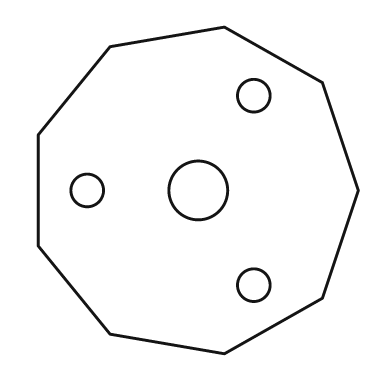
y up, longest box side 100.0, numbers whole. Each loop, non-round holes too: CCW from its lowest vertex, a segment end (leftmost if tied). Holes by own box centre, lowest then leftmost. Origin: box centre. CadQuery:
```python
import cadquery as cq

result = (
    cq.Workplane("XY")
    .moveTo(8.0, -50.0)
    .lineTo(38.0, -33.0)
    .lineTo(49.0, 0.0)
    .lineTo(38.0, 33.0)
    .lineTo(8.0, 50.0)
    .lineTo(-27.0, 44.0)
    .lineTo(-49.0, 17.0)
    .lineTo(-49.0, -17.0)
    .lineTo(-27.0, -44.0)
    .close()
    .moveTo(17.0, -29.0)
    .circle(5.0)
    .moveTo(-34.0, 0.0)
    .circle(5.0)
    .moveTo(0.0, 0.0)
    .circle(9.0)
    .moveTo(17.0, 29.0)
    .circle(5.0)
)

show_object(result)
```